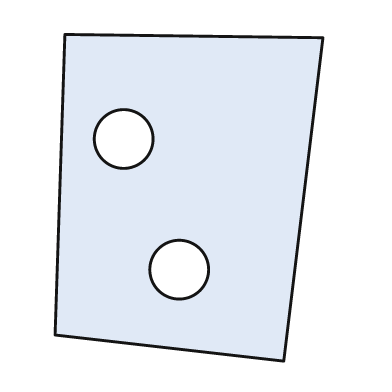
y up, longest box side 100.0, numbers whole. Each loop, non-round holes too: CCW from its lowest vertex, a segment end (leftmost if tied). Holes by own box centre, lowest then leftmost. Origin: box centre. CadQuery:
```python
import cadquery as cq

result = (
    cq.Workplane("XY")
    .moveTo(29.0, -50.0)
    .lineTo(41.0, 49.0)
    .lineTo(-38.0, 50.0)
    .lineTo(-41.0, -42.0)
    .close()
    .moveTo(-3.0, -22.0)
    .circle(9.0)
    .moveTo(-20.0, 18.0)
    .circle(9.0)
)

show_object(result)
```